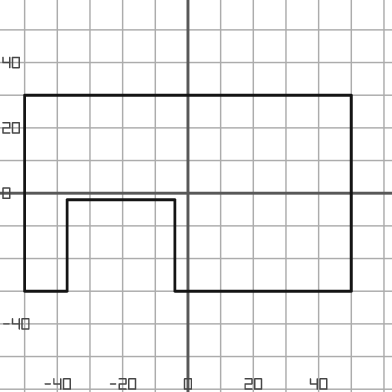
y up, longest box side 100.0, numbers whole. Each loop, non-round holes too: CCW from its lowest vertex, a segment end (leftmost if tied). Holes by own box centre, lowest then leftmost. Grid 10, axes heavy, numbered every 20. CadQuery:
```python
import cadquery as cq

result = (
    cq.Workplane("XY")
    .moveTo(-50.0, -30.0)
    .lineTo(-37.0, -30.0)
    .lineTo(-37.0, -2.0)
    .lineTo(-4.0, -2.0)
    .lineTo(-4.0, -30.0)
    .lineTo(50.0, -30.0)
    .lineTo(50.0, 30.0)
    .lineTo(-50.0, 30.0)
    .close()
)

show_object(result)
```